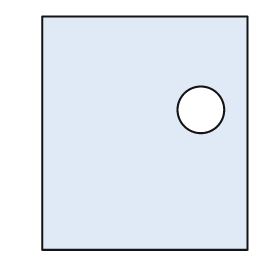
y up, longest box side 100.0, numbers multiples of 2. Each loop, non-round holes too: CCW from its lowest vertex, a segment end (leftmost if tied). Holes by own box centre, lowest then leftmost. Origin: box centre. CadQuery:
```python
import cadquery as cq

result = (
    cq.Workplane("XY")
    .moveTo(-44.0, -50.0)
    .lineTo(44.0, -50.0)
    .lineTo(44.0, 50.0)
    .lineTo(-44.0, 50.0)
    .close()
    .moveTo(24.0, 10.0)
    .circle(10.0)
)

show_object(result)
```